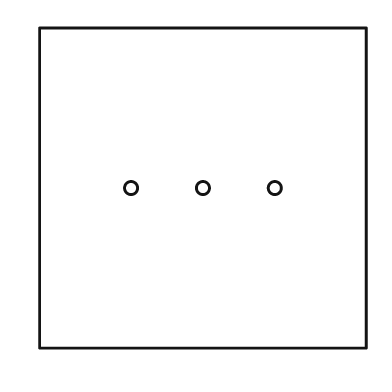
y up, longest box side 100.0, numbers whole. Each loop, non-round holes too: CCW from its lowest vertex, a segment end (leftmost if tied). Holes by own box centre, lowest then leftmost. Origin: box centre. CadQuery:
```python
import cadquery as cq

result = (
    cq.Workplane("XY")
    .moveTo(-50.0, -49.0)
    .lineTo(50.0, -49.0)
    .lineTo(50.0, 49.0)
    .lineTo(-50.0, 49.0)
    .close()
    .moveTo(-22.0, 0.0)
    .circle(2.0)
    .moveTo(0.0, 0.0)
    .circle(2.0)
    .moveTo(22.0, 0.0)
    .circle(2.0)
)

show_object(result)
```